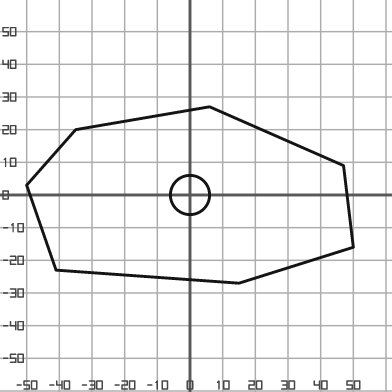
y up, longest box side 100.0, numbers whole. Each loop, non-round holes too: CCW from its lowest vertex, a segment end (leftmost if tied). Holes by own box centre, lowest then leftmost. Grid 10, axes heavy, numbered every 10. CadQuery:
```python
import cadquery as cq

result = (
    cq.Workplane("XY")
    .moveTo(15.0, -27.0)
    .lineTo(50.0, -16.0)
    .lineTo(47.0, 9.0)
    .lineTo(6.0, 27.0)
    .lineTo(-35.0, 20.0)
    .lineTo(-50.0, 3.0)
    .lineTo(-41.0, -23.0)
    .close()
    .moveTo(0.0, 0.0)
    .circle(6.0)
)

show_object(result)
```